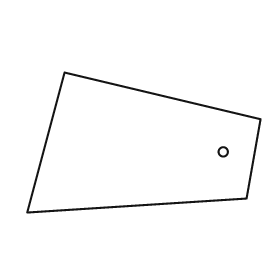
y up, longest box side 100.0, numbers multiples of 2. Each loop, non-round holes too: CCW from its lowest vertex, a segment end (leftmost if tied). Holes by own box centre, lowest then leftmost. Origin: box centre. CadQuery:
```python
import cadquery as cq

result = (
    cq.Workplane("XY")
    .moveTo(-50.0, -30.0)
    .lineTo(44.0, -24.0)
    .lineTo(50.0, 10.0)
    .lineTo(-34.0, 30.0)
    .close()
    .moveTo(34.0, -4.0)
    .circle(2.0)
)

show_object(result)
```